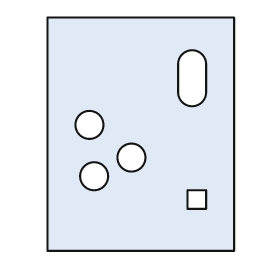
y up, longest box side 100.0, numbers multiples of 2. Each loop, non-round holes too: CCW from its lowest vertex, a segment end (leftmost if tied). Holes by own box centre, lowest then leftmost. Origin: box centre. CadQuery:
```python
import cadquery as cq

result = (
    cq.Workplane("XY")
    .moveTo(-40.0, -50.0)
    .lineTo(40.0, -50.0)
    .lineTo(40.0, 50.0)
    .lineTo(-40.0, 50.0)
    .close()
    .moveTo(20.0, -32.0)
    .lineTo(28.0, -32.0)
    .lineTo(28.0, -24.0)
    .lineTo(20.0, -24.0)
    .close()
    .moveTo(-20.0, -18.0)
    .circle(6.0)
    .moveTo(-4.0, -10.0)
    .circle(6.0)
    .moveTo(-22.0, 4.0)
    .circle(6.0)
    .moveTo(16.0, 18.0)
    .threePointArc((22.0, 12.0), (28.0, 18.0))
    .lineTo(28.0, 30.0)
    .threePointArc((22.0, 36.0), (16.0, 30.0))
    .close()
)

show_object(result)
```